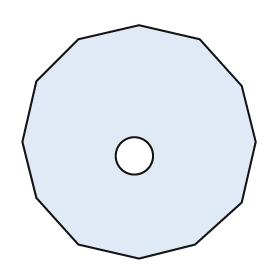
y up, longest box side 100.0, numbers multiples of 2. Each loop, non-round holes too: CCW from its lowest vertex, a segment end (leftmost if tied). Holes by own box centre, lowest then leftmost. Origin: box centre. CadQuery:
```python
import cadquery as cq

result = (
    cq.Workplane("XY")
    .moveTo(0.0, -50.0)
    .lineTo(24.0, -44.0)
    .lineTo(44.0, -26.0)
    .lineTo(50.0, 0.0)
    .lineTo(44.0, 24.0)
    .lineTo(26.0, 44.0)
    .lineTo(0.0, 50.0)
    .lineTo(-26.0, 44.0)
    .lineTo(-44.0, 26.0)
    .lineTo(-50.0, 0.0)
    .lineTo(-44.0, -24.0)
    .lineTo(-26.0, -44.0)
    .close()
    .moveTo(-2.0, -6.0)
    .circle(8.0)
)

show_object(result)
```